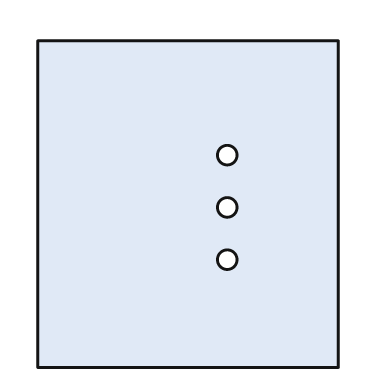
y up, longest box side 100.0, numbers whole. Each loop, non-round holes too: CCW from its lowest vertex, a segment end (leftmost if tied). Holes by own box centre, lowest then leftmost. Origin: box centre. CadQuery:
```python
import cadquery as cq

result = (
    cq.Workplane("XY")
    .moveTo(-46.0, -50.0)
    .lineTo(46.0, -50.0)
    .lineTo(46.0, 50.0)
    .lineTo(-46.0, 50.0)
    .close()
    .moveTo(12.0, -17.0)
    .circle(3.0)
    .moveTo(12.0, -1.0)
    .circle(3.0)
    .moveTo(12.0, 15.0)
    .circle(3.0)
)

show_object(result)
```